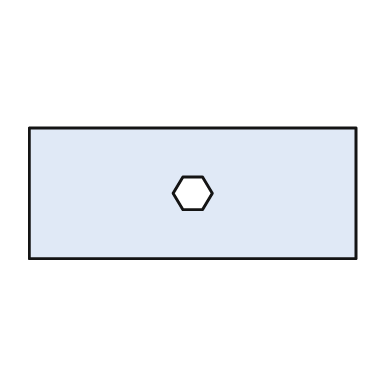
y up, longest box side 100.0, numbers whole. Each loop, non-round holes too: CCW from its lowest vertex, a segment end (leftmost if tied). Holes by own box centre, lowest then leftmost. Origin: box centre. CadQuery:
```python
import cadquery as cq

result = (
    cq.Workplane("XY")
    .moveTo(-50.0, -20.0)
    .lineTo(50.0, -20.0)
    .lineTo(50.0, 20.0)
    .lineTo(-50.0, 20.0)
    .close()
    .moveTo(-3.0, -5.0)
    .lineTo(3.0, -5.0)
    .lineTo(6.0, 0.0)
    .lineTo(3.0, 5.0)
    .lineTo(-3.0, 5.0)
    .lineTo(-6.0, 0.0)
    .close()
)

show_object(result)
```